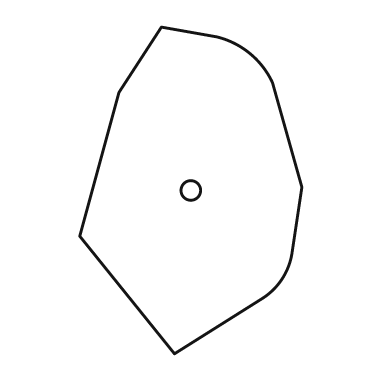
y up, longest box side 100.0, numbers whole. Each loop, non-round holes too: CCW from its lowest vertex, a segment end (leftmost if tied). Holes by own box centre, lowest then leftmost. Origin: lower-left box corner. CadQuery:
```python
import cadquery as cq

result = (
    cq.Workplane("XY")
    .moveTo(29.0, 0.0)
    .lineTo(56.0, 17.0)
    .threePointArc((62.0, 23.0), (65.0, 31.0))
    .lineTo(68.0, 51.0)
    .lineTo(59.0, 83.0)
    .threePointArc((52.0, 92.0), (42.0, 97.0))
    .lineTo(25.0, 100.0)
    .lineTo(12.0, 80.0)
    .lineTo(0.0, 36.0)
    .close()
    .moveTo(34.0, 50.0)
    .circle(3.0)
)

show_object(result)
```